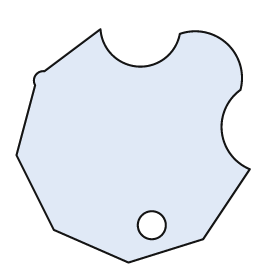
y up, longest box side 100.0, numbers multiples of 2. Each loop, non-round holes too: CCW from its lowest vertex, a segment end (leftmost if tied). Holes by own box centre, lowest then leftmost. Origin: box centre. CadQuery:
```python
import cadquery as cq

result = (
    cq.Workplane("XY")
    .moveTo(-2.0, -50.0)
    .lineTo(30.0, -40.0)
    .lineTo(50.0, -10.0)
    .threePointArc((38.0, 6.0), (46.0, 24.0))
    .threePointArc((40.0, 44.0), (20.0, 48.0))
    .threePointArc((2.0, 34.0), (-14.0, 50.0))
    .lineTo(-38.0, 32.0)
    .threePointArc((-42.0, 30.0), (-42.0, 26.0))
    .lineTo(-50.0, -4.0)
    .lineTo(-34.0, -36.0)
    .close()
    .moveTo(8.0, -34.0)
    .circle(6.0)
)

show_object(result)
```